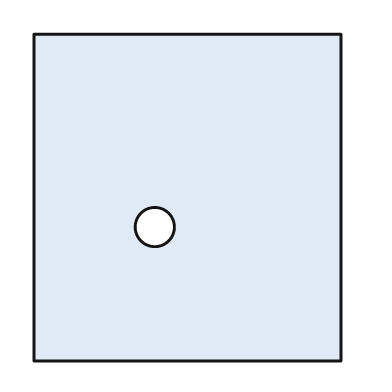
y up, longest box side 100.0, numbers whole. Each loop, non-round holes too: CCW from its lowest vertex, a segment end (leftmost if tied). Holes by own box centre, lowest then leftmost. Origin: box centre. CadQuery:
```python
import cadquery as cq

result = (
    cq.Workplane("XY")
    .moveTo(-47.0, -50.0)
    .lineTo(47.0, -50.0)
    .lineTo(47.0, 50.0)
    .lineTo(-47.0, 50.0)
    .close()
    .moveTo(-10.0, -9.0)
    .circle(6.0)
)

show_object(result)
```